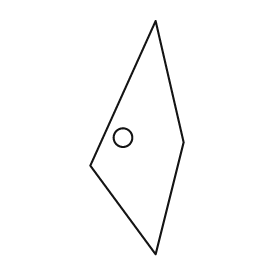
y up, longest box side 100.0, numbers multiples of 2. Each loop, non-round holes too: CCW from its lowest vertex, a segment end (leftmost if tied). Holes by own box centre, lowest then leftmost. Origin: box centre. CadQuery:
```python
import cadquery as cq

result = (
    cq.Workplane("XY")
    .moveTo(8.0, -50.0)
    .lineTo(20.0, -2.0)
    .lineTo(8.0, 50.0)
    .lineTo(-20.0, -12.0)
    .close()
    .moveTo(-6.0, 0.0)
    .circle(4.0)
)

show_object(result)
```